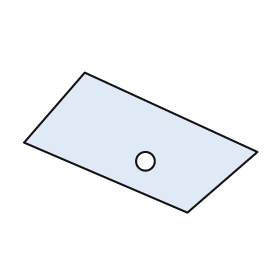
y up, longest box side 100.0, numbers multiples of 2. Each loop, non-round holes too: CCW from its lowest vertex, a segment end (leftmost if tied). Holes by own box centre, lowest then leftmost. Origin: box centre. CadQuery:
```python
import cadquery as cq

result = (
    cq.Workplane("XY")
    .moveTo(20.0, -30.0)
    .lineTo(50.0, -4.0)
    .lineTo(-24.0, 30.0)
    .lineTo(-50.0, 0.0)
    .close()
    .moveTo(2.0, -8.0)
    .circle(4.0)
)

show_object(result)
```